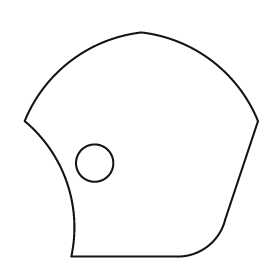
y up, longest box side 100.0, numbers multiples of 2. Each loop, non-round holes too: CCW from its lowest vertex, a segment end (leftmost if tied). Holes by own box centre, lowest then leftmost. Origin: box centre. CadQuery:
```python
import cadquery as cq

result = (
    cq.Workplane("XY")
    .moveTo(-30.0, -48.0)
    .lineTo(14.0, -48.0)
    .threePointArc((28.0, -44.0), (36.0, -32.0))
    .lineTo(50.0, 10.0)
    .threePointArc((30.0, 36.0), (0.0, 48.0))
    .threePointArc((-30.0, 36.0), (-50.0, 10.0))
    .threePointArc((-32.0, -16.0), (-30.0, -48.0))
    .close()
    .moveTo(-20.0, -8.0)
    .circle(8.0)
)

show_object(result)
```